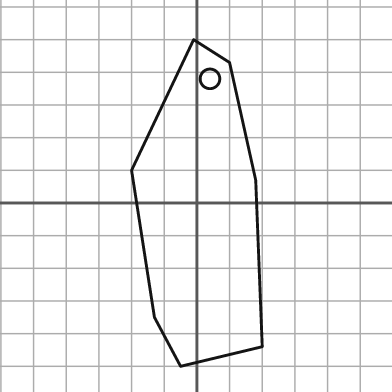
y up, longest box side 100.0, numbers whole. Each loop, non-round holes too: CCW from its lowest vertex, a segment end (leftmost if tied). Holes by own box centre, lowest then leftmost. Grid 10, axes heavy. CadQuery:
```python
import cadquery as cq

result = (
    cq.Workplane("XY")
    .moveTo(-5.0, -50.0)
    .lineTo(20.0, -44.0)
    .lineTo(18.0, 7.0)
    .lineTo(10.0, 43.0)
    .lineTo(-1.0, 50.0)
    .lineTo(-20.0, 10.0)
    .lineTo(-13.0, -35.0)
    .close()
    .moveTo(4.0, 38.0)
    .circle(3.0)
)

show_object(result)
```